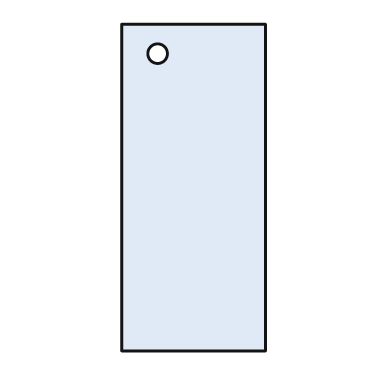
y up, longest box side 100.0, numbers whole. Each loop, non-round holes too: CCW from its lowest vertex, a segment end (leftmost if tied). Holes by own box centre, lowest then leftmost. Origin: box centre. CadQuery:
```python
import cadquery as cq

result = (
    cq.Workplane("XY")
    .moveTo(-22.0, -50.0)
    .lineTo(22.0, -50.0)
    .lineTo(22.0, 50.0)
    .lineTo(-22.0, 50.0)
    .close()
    .moveTo(-11.0, 41.0)
    .circle(3.0)
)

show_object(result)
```